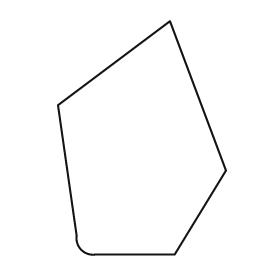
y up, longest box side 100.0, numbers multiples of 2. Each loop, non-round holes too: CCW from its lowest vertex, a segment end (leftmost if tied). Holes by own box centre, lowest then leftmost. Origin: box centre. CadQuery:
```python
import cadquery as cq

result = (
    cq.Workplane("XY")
    .moveTo(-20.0, -50.0)
    .lineTo(14.0, -50.0)
    .lineTo(36.0, -14.0)
    .lineTo(12.0, 50.0)
    .lineTo(-36.0, 14.0)
    .lineTo(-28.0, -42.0)
    .threePointArc((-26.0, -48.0), (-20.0, -50.0))
    .close()
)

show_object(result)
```